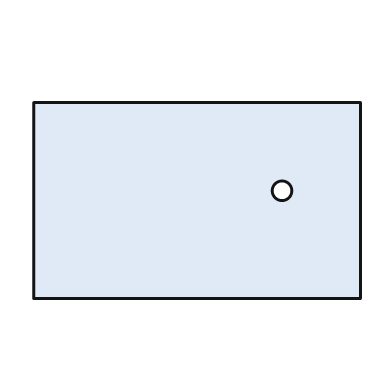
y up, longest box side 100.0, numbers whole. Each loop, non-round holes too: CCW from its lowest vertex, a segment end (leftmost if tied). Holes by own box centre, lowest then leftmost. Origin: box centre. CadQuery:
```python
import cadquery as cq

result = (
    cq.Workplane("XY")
    .moveTo(-50.0, -30.0)
    .lineTo(50.0, -30.0)
    .lineTo(50.0, 30.0)
    .lineTo(-50.0, 30.0)
    .close()
    .moveTo(26.0, 3.0)
    .circle(3.0)
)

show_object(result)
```